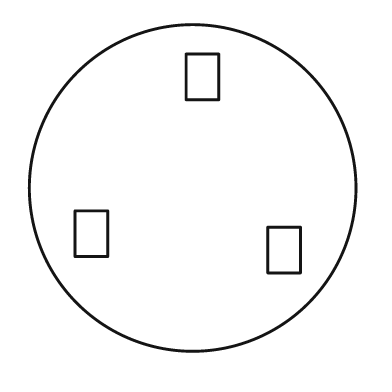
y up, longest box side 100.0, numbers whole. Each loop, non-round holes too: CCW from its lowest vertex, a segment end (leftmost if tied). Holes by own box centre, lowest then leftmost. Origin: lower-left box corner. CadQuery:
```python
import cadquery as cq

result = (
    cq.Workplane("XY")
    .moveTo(50.0, 50.0)
    .circle(50.0)
    .moveTo(73.0, 24.0)
    .lineTo(83.0, 24.0)
    .lineTo(83.0, 38.0)
    .lineTo(73.0, 38.0)
    .close()
    .moveTo(14.0, 29.0)
    .lineTo(24.0, 29.0)
    .lineTo(24.0, 43.0)
    .lineTo(14.0, 43.0)
    .close()
    .moveTo(48.0, 77.0)
    .lineTo(58.0, 77.0)
    .lineTo(58.0, 91.0)
    .lineTo(48.0, 91.0)
    .close()
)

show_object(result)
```